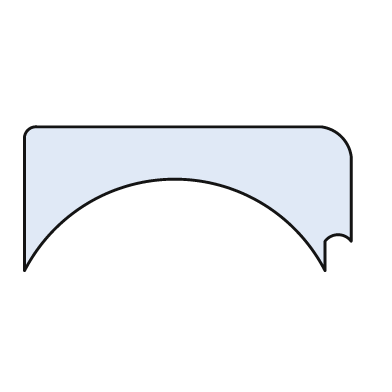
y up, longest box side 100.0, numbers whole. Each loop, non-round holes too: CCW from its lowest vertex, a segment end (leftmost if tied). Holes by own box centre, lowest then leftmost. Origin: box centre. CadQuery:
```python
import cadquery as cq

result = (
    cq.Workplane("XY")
    .moveTo(-50.0, -22.0)
    .threePointArc((-4.0, 6.0), (42.0, -22.0))
    .lineTo(42.0, -13.0)
    .threePointArc((46.0, -11.0), (50.0, -13.0))
    .lineTo(50.0, 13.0)
    .threePointArc((47.0, 19.0), (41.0, 22.0))
    .lineTo(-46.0, 22.0)
    .threePointArc((-49.0, 21.0), (-50.0, 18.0))
    .close()
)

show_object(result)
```